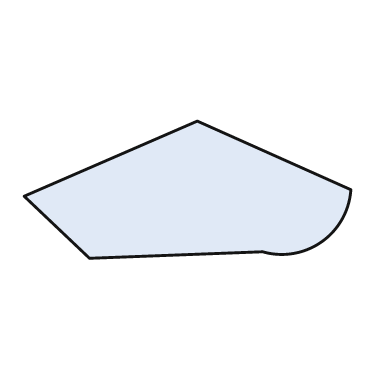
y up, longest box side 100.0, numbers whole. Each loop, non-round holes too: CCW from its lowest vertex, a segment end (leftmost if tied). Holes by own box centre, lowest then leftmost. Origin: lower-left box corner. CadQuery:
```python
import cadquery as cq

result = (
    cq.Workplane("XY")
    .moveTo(20.0, 0.0)
    .lineTo(73.0, 2.0)
    .threePointArc((91.0, 5.0), (100.0, 21.0))
    .lineTo(53.0, 42.0)
    .lineTo(0.0, 19.0)
    .close()
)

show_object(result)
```